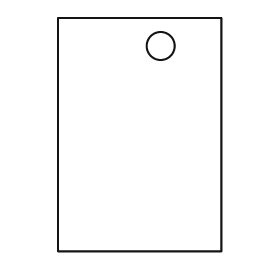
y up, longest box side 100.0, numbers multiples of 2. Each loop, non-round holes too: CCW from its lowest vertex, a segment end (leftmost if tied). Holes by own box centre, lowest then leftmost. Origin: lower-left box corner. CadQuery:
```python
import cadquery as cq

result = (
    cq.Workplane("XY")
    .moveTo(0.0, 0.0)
    .lineTo(70.0, 0.0)
    .lineTo(70.0, 100.0)
    .lineTo(0.0, 100.0)
    .close()
    .moveTo(44.0, 88.0)
    .circle(6.0)
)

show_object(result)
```